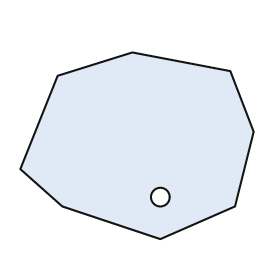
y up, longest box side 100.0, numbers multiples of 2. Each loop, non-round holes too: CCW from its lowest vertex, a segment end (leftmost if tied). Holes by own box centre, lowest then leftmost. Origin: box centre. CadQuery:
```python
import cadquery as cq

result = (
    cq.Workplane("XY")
    .moveTo(10.0, -40.0)
    .lineTo(42.0, -26.0)
    .lineTo(50.0, 6.0)
    .lineTo(40.0, 32.0)
    .lineTo(-2.0, 40.0)
    .lineTo(-34.0, 30.0)
    .lineTo(-50.0, -10.0)
    .lineTo(-32.0, -26.0)
    .close()
    .moveTo(10.0, -22.0)
    .circle(4.0)
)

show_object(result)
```